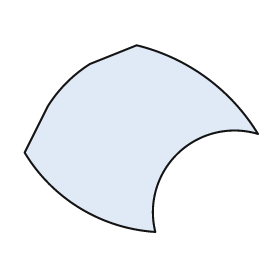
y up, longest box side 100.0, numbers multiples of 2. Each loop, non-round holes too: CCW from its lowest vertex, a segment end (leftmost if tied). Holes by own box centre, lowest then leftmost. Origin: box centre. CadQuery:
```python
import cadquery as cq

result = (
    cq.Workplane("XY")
    .moveTo(6.0, -40.0)
    .threePointArc((16.0, -6.0), (50.0, 2.0))
    .threePointArc((28.0, 26.0), (-2.0, 40.0))
    .lineTo(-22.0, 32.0)
    .threePointArc((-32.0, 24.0), (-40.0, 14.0))
    .lineTo(-50.0, -6.0)
    .threePointArc((-26.0, -30.0), (6.0, -40.0))
    .close()
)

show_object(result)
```